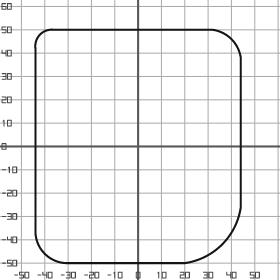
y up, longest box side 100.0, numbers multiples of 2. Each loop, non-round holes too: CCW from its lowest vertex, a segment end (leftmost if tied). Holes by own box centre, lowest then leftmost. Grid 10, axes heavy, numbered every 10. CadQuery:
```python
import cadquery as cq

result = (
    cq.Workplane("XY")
    .moveTo(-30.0, -50.0)
    .lineTo(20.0, -50.0)
    .threePointArc((36.0, -42.0), (44.0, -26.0))
    .lineTo(44.0, 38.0)
    .threePointArc((40.0, 46.0), (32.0, 50.0))
    .lineTo(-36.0, 50.0)
    .threePointArc((-42.0, 48.0), (-44.0, 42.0))
    .lineTo(-44.0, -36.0)
    .threePointArc((-40.0, -46.0), (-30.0, -50.0))
    .close()
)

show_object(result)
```